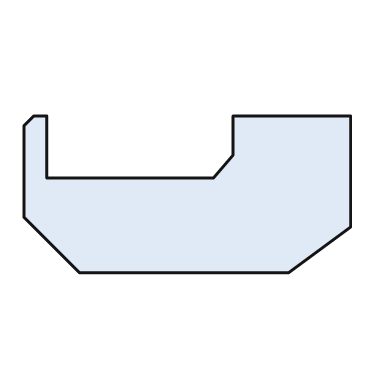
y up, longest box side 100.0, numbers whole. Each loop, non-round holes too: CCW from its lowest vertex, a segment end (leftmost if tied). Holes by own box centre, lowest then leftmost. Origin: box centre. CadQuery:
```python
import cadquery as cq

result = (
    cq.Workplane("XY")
    .moveTo(-33.0, -24.0)
    .lineTo(31.0, -24.0)
    .lineTo(50.0, -10.0)
    .lineTo(50.0, 24.0)
    .lineTo(14.0, 24.0)
    .lineTo(14.0, 12.0)
    .lineTo(8.0, 5.0)
    .lineTo(-43.0, 5.0)
    .lineTo(-43.0, 24.0)
    .lineTo(-47.0, 24.0)
    .lineTo(-50.0, 21.0)
    .lineTo(-50.0, -7.0)
    .close()
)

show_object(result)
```